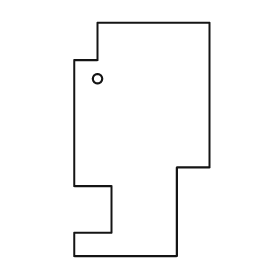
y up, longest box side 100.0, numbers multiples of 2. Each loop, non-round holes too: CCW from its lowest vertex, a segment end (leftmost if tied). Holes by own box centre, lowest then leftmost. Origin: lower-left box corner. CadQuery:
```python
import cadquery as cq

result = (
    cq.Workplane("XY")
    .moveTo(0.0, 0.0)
    .lineTo(44.0, 0.0)
    .lineTo(44.0, 38.0)
    .lineTo(58.0, 38.0)
    .lineTo(58.0, 100.0)
    .lineTo(10.0, 100.0)
    .lineTo(10.0, 84.0)
    .lineTo(0.0, 84.0)
    .lineTo(0.0, 30.0)
    .lineTo(16.0, 30.0)
    .lineTo(16.0, 10.0)
    .lineTo(0.0, 10.0)
    .close()
    .moveTo(10.0, 76.0)
    .circle(2.0)
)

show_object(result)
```